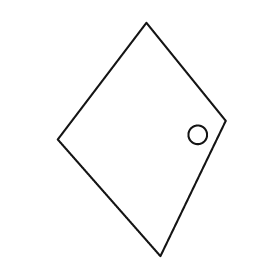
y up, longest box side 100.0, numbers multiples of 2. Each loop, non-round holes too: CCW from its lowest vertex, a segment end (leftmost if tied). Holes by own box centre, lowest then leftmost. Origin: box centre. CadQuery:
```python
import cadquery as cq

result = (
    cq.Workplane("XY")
    .moveTo(8.0, -50.0)
    .lineTo(36.0, 8.0)
    .lineTo(2.0, 50.0)
    .lineTo(-36.0, 0.0)
    .close()
    .moveTo(24.0, 2.0)
    .circle(4.0)
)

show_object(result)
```